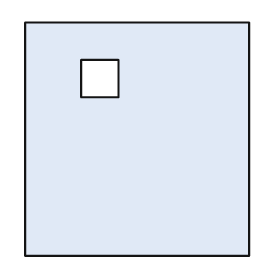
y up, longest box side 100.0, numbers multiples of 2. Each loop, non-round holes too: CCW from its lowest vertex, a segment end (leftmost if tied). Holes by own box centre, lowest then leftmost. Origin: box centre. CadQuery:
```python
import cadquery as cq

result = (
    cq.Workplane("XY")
    .moveTo(-48.0, -50.0)
    .lineTo(48.0, -50.0)
    .lineTo(48.0, 50.0)
    .lineTo(-48.0, 50.0)
    .close()
    .moveTo(-24.0, 18.0)
    .lineTo(-8.0, 18.0)
    .lineTo(-8.0, 34.0)
    .lineTo(-24.0, 34.0)
    .close()
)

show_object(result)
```